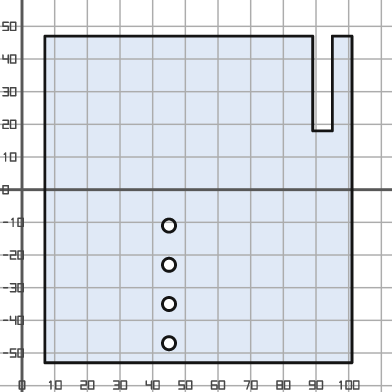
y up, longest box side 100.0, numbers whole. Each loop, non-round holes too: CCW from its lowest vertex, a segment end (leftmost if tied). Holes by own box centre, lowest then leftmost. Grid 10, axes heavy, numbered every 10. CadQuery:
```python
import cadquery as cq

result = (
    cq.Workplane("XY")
    .moveTo(7.0, -53.0)
    .lineTo(101.0, -53.0)
    .lineTo(101.0, 47.0)
    .lineTo(95.0, 47.0)
    .lineTo(95.0, 18.0)
    .lineTo(89.0, 18.0)
    .lineTo(89.0, 47.0)
    .lineTo(7.0, 47.0)
    .close()
    .moveTo(45.0, -47.0)
    .circle(2.0)
    .moveTo(45.0, -35.0)
    .circle(2.0)
    .moveTo(45.0, -23.0)
    .circle(2.0)
    .moveTo(45.0, -11.0)
    .circle(2.0)
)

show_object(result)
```